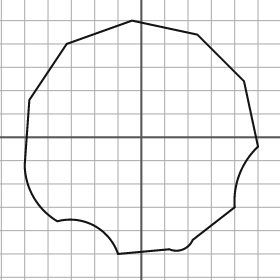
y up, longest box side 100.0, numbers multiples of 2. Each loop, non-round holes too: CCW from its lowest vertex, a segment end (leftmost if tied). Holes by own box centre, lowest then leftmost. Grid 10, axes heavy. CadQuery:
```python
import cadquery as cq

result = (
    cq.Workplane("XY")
    .moveTo(-10.0, -50.0)
    .lineTo(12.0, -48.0)
    .threePointArc((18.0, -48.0), (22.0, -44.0))
    .lineTo(40.0, -30.0)
    .threePointArc((42.0, -16.0), (50.0, -4.0))
    .lineTo(44.0, 24.0)
    .lineTo(24.0, 44.0)
    .lineTo(-4.0, 50.0)
    .lineTo(-32.0, 40.0)
    .lineTo(-48.0, 16.0)
    .lineTo(-50.0, -12.0)
    .threePointArc((-46.0, -26.0), (-36.0, -36.0))
    .threePointArc((-20.0, -38.0), (-10.0, -50.0))
    .close()
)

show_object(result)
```